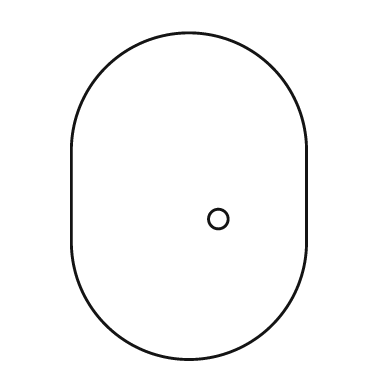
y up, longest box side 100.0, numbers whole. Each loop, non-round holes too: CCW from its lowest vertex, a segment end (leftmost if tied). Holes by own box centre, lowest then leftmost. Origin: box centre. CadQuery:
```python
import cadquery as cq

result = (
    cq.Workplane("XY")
    .moveTo(-36.0, -14.0)
    .threePointArc((0.0, -50.0), (36.0, -14.0))
    .lineTo(36.0, 14.0)
    .threePointArc((0.0, 50.0), (-36.0, 14.0))
    .close()
    .moveTo(9.0, -7.0)
    .circle(3.0)
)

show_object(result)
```